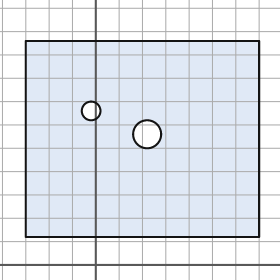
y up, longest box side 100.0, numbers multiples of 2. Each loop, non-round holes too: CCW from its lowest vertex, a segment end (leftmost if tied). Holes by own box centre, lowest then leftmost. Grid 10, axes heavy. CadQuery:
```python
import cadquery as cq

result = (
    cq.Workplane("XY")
    .moveTo(-30.0, 12.0)
    .lineTo(70.0, 12.0)
    .lineTo(70.0, 96.0)
    .lineTo(-30.0, 96.0)
    .close()
    .moveTo(22.0, 56.0)
    .circle(6.0)
    .moveTo(-2.0, 66.0)
    .circle(4.0)
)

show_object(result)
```